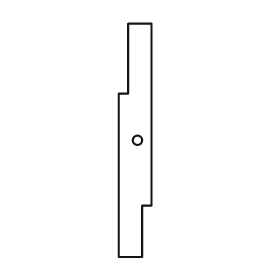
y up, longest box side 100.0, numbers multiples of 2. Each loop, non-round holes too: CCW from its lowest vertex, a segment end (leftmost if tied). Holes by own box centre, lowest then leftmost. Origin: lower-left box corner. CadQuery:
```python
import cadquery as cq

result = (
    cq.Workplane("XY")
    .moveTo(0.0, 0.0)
    .lineTo(10.0, 0.0)
    .lineTo(10.0, 22.0)
    .lineTo(14.0, 22.0)
    .lineTo(14.0, 100.0)
    .lineTo(4.0, 100.0)
    .lineTo(4.0, 70.0)
    .lineTo(0.0, 70.0)
    .close()
    .moveTo(8.0, 50.0)
    .circle(2.0)
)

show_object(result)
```